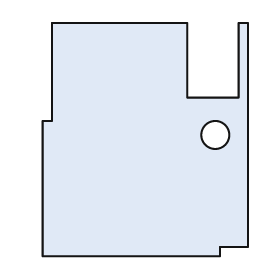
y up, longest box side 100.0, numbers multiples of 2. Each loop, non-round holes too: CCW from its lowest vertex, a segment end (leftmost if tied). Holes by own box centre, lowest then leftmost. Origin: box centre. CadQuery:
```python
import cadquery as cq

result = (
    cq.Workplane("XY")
    .moveTo(-44.0, -50.0)
    .lineTo(32.0, -50.0)
    .lineTo(32.0, -46.0)
    .lineTo(44.0, -46.0)
    .lineTo(44.0, 50.0)
    .lineTo(40.0, 50.0)
    .lineTo(40.0, 18.0)
    .lineTo(18.0, 18.0)
    .lineTo(18.0, 50.0)
    .lineTo(-40.0, 50.0)
    .lineTo(-40.0, 8.0)
    .lineTo(-44.0, 8.0)
    .close()
    .moveTo(30.0, 2.0)
    .circle(6.0)
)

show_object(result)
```